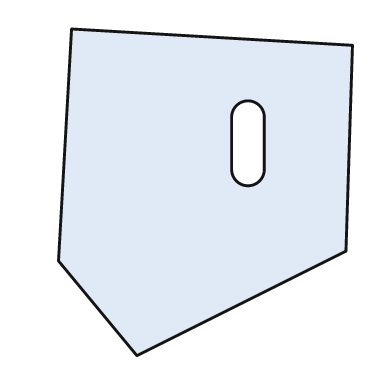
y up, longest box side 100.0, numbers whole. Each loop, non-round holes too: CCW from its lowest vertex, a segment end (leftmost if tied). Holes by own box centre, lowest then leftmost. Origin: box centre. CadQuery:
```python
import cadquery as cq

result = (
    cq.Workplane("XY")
    .moveTo(-21.0, -50.0)
    .lineTo(43.0, -18.0)
    .lineTo(45.0, 45.0)
    .lineTo(-41.0, 50.0)
    .lineTo(-45.0, -21.0)
    .close()
    .moveTo(8.0, 7.0)
    .threePointArc((13.0, 2.0), (18.0, 7.0))
    .lineTo(18.0, 23.0)
    .threePointArc((13.0, 28.0), (8.0, 23.0))
    .close()
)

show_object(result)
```